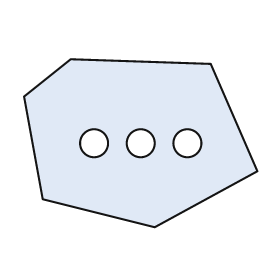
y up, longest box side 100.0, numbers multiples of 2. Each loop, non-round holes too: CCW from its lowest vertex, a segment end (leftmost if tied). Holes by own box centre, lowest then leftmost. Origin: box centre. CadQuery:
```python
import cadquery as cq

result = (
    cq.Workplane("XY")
    .moveTo(6.0, -36.0)
    .lineTo(50.0, -12.0)
    .lineTo(30.0, 34.0)
    .lineTo(-30.0, 36.0)
    .lineTo(-50.0, 20.0)
    .lineTo(-42.0, -24.0)
    .close()
    .moveTo(-20.0, 0.0)
    .circle(6.0)
    .moveTo(0.0, 0.0)
    .circle(6.0)
    .moveTo(20.0, 0.0)
    .circle(6.0)
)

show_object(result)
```